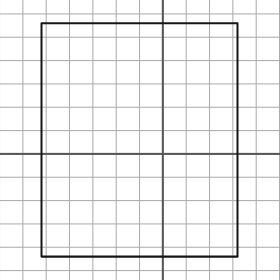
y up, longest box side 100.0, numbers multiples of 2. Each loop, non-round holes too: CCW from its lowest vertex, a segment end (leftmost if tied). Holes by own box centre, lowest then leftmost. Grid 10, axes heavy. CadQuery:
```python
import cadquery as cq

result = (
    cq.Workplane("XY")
    .moveTo(-52.0, -44.0)
    .lineTo(32.0, -44.0)
    .lineTo(32.0, 56.0)
    .lineTo(-52.0, 56.0)
    .close()
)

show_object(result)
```